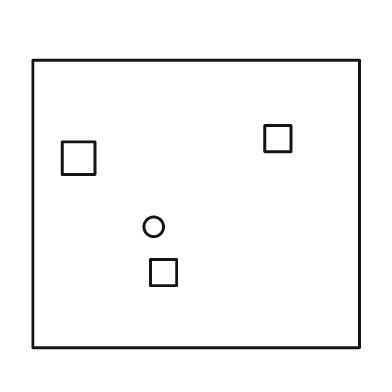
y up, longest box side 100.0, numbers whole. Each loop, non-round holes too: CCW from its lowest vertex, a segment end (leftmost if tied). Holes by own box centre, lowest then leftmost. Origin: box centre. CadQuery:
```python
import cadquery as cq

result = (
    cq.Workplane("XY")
    .moveTo(-50.0, -44.0)
    .lineTo(50.0, -44.0)
    .lineTo(50.0, 44.0)
    .lineTo(-50.0, 44.0)
    .close()
    .moveTo(-14.0, -25.0)
    .lineTo(-6.0, -25.0)
    .lineTo(-6.0, -17.0)
    .lineTo(-14.0, -17.0)
    .close()
    .moveTo(-13.0, -7.0)
    .circle(3.0)
    .moveTo(-41.0, 9.0)
    .lineTo(-31.0, 9.0)
    .lineTo(-31.0, 19.0)
    .lineTo(-41.0, 19.0)
    .close()
    .moveTo(21.0, 16.0)
    .lineTo(29.0, 16.0)
    .lineTo(29.0, 24.0)
    .lineTo(21.0, 24.0)
    .close()
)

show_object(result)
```